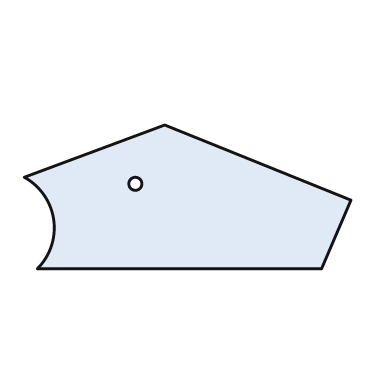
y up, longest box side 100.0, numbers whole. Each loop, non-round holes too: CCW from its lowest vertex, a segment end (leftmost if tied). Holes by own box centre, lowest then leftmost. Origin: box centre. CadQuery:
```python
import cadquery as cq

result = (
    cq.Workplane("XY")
    .moveTo(-46.0, -22.0)
    .lineTo(41.0, -22.0)
    .lineTo(50.0, -1.0)
    .lineTo(-7.0, 22.0)
    .lineTo(-50.0, 6.0)
    .threePointArc((-41.0, -7.0), (-46.0, -22.0))
    .close()
    .moveTo(-16.0, 4.0)
    .circle(2.0)
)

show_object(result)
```